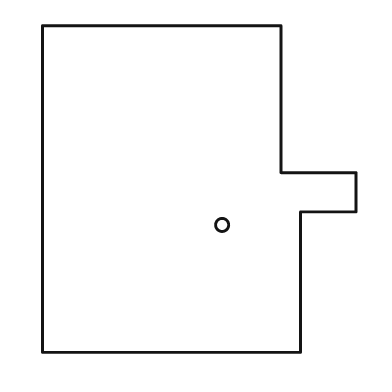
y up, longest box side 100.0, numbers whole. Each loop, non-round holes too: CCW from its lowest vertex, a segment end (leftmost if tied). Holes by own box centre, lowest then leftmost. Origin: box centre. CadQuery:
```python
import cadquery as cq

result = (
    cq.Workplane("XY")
    .moveTo(-48.0, -50.0)
    .lineTo(31.0, -50.0)
    .lineTo(31.0, -7.0)
    .lineTo(48.0, -7.0)
    .lineTo(48.0, 5.0)
    .lineTo(25.0, 5.0)
    .lineTo(25.0, 50.0)
    .lineTo(-48.0, 50.0)
    .close()
    .moveTo(7.0, -11.0)
    .circle(2.0)
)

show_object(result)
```